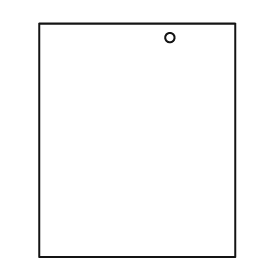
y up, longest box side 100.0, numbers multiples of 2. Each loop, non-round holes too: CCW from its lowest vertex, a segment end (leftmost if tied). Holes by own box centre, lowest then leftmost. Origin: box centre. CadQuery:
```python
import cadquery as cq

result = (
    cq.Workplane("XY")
    .moveTo(-42.0, -50.0)
    .lineTo(42.0, -50.0)
    .lineTo(42.0, 50.0)
    .lineTo(-42.0, 50.0)
    .close()
    .moveTo(14.0, 44.0)
    .circle(2.0)
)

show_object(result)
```